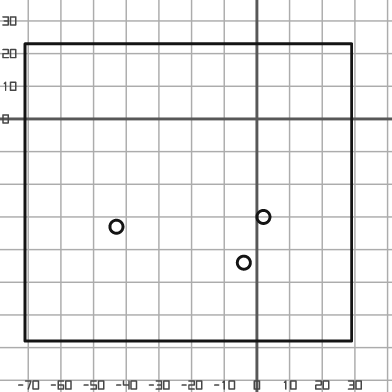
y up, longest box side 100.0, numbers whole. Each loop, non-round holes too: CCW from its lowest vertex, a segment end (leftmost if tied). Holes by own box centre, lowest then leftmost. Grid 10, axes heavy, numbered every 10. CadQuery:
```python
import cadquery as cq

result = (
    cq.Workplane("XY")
    .moveTo(-71.0, -68.0)
    .lineTo(29.0, -68.0)
    .lineTo(29.0, 23.0)
    .lineTo(-71.0, 23.0)
    .close()
    .moveTo(-4.0, -44.0)
    .circle(2.0)
    .moveTo(-43.0, -33.0)
    .circle(2.0)
    .moveTo(2.0, -30.0)
    .circle(2.0)
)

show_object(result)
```